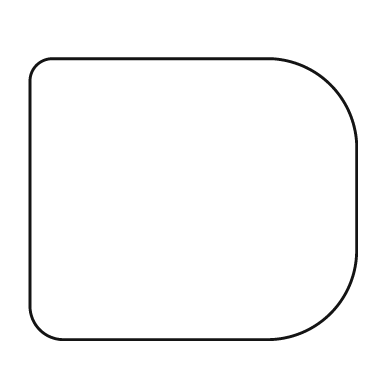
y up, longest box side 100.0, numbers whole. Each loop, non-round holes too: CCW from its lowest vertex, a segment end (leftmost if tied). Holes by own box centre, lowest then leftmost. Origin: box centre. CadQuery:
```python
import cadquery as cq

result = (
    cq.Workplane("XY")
    .moveTo(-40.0, -43.0)
    .lineTo(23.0, -43.0)
    .threePointArc((42.0, -35.0), (50.0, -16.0))
    .lineTo(50.0, 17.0)
    .threePointArc((42.0, 35.0), (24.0, 43.0))
    .lineTo(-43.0, 43.0)
    .threePointArc((-48.0, 41.0), (-50.0, 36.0))
    .lineTo(-50.0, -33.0)
    .threePointArc((-47.0, -40.0), (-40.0, -43.0))
    .close()
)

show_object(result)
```